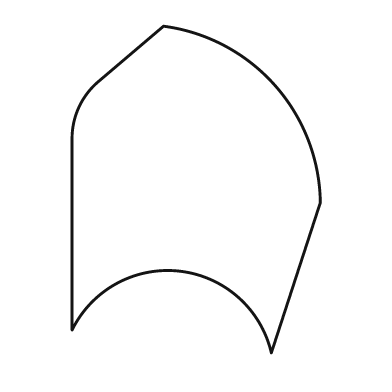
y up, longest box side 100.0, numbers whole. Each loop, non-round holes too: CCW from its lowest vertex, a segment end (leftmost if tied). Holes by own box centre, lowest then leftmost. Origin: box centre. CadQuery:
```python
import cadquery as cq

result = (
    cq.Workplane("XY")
    .moveTo(23.0, -50.0)
    .lineTo(38.0, -4.0)
    .threePointArc((24.0, 32.0), (-10.0, 50.0))
    .lineTo(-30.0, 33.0)
    .threePointArc((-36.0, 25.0), (-38.0, 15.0))
    .lineTo(-38.0, -43.0)
    .threePointArc((-5.0, -25.0), (23.0, -50.0))
    .close()
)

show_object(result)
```